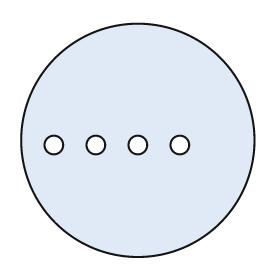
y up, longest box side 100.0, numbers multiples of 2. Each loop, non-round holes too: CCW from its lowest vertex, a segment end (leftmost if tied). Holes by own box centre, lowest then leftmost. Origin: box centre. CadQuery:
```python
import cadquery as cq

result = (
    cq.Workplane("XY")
    .moveTo(0.0, 0.0)
    .circle(50.0)
    .moveTo(-36.0, -2.0)
    .circle(4.0)
    .moveTo(-18.0, -2.0)
    .circle(4.0)
    .moveTo(0.0, -2.0)
    .circle(4.0)
    .moveTo(18.0, -2.0)
    .circle(4.0)
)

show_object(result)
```